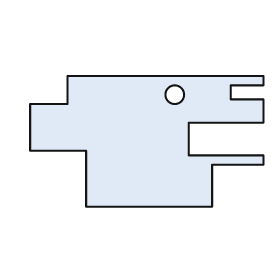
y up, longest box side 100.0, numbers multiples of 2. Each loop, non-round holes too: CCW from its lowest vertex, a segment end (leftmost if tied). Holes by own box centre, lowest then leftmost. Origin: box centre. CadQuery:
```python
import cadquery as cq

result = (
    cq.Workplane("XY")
    .moveTo(-26.0, -28.0)
    .lineTo(28.0, -28.0)
    .lineTo(28.0, -10.0)
    .lineTo(50.0, -10.0)
    .lineTo(50.0, -6.0)
    .lineTo(18.0, -6.0)
    .lineTo(18.0, 8.0)
    .lineTo(50.0, 8.0)
    .lineTo(50.0, 18.0)
    .lineTo(36.0, 18.0)
    .lineTo(36.0, 24.0)
    .lineTo(50.0, 24.0)
    .lineTo(50.0, 28.0)
    .lineTo(-34.0, 28.0)
    .lineTo(-34.0, 16.0)
    .lineTo(-50.0, 16.0)
    .lineTo(-50.0, -4.0)
    .lineTo(-26.0, -4.0)
    .close()
    .moveTo(12.0, 20.0)
    .circle(4.0)
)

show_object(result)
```